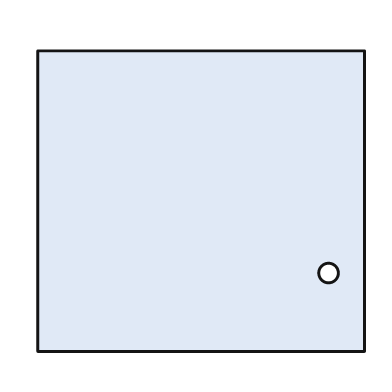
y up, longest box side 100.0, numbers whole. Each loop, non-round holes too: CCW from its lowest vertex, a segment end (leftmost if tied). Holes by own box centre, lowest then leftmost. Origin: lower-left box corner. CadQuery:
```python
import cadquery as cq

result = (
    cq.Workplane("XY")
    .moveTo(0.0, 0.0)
    .lineTo(100.0, 0.0)
    .lineTo(100.0, 92.0)
    .lineTo(0.0, 92.0)
    .close()
    .moveTo(89.0, 24.0)
    .circle(3.0)
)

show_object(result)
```